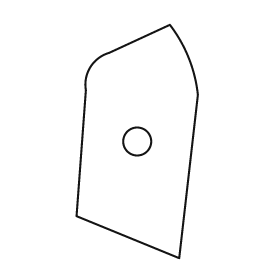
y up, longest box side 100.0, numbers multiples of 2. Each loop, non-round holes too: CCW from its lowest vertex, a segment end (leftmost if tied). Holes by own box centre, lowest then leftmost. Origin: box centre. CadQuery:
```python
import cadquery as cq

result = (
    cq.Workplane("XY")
    .moveTo(18.0, -50.0)
    .lineTo(26.0, 20.0)
    .threePointArc((22.0, 36.0), (14.0, 50.0))
    .lineTo(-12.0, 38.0)
    .threePointArc((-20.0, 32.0), (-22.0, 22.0))
    .lineTo(-26.0, -32.0)
    .close()
    .moveTo(0.0, 0.0)
    .circle(6.0)
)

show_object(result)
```